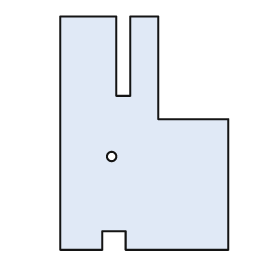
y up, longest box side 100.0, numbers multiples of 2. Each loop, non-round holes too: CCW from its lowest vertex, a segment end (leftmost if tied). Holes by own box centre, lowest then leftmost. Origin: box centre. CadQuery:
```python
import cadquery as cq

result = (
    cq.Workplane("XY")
    .moveTo(-36.0, -50.0)
    .lineTo(-18.0, -50.0)
    .lineTo(-18.0, -42.0)
    .lineTo(-8.0, -42.0)
    .lineTo(-8.0, -50.0)
    .lineTo(36.0, -50.0)
    .lineTo(36.0, 6.0)
    .lineTo(6.0, 6.0)
    .lineTo(6.0, 50.0)
    .lineTo(-6.0, 50.0)
    .lineTo(-6.0, 16.0)
    .lineTo(-12.0, 16.0)
    .lineTo(-12.0, 50.0)
    .lineTo(-36.0, 50.0)
    .close()
    .moveTo(-14.0, -10.0)
    .circle(2.0)
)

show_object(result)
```